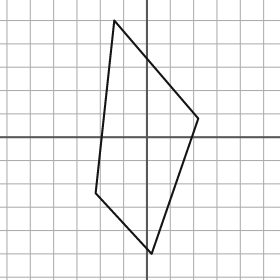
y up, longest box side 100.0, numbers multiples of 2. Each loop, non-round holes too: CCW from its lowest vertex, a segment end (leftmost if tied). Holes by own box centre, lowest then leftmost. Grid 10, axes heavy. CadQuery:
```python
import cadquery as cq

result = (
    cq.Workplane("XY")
    .moveTo(2.0, -50.0)
    .lineTo(22.0, 8.0)
    .lineTo(-14.0, 50.0)
    .lineTo(-22.0, -24.0)
    .close()
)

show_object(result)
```